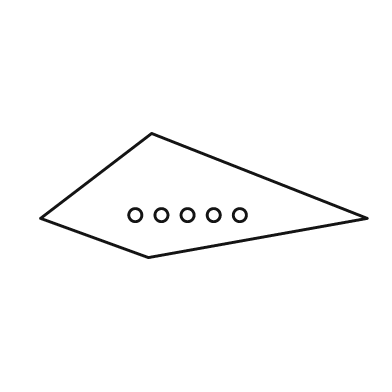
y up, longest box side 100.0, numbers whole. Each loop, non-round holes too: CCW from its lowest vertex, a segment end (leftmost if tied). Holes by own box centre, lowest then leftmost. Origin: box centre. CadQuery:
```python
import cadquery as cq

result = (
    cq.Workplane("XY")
    .moveTo(-17.0, -19.0)
    .lineTo(50.0, -7.0)
    .lineTo(-16.0, 19.0)
    .lineTo(-50.0, -7.0)
    .close()
    .moveTo(-21.0, -6.0)
    .circle(2.0)
    .moveTo(-13.0, -6.0)
    .circle(2.0)
    .moveTo(-5.0, -6.0)
    .circle(2.0)
    .moveTo(3.0, -6.0)
    .circle(2.0)
    .moveTo(11.0, -6.0)
    .circle(2.0)
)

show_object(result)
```